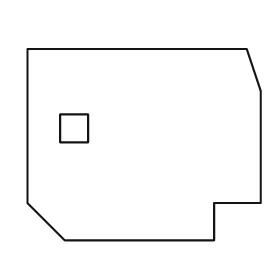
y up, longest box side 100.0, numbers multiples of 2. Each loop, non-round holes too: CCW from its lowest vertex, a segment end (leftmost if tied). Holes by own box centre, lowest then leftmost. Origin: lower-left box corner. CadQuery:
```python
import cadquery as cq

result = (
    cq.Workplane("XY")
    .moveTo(16.0, 0.0)
    .lineTo(80.0, 0.0)
    .lineTo(80.0, 16.0)
    .lineTo(100.0, 16.0)
    .lineTo(100.0, 64.0)
    .lineTo(94.0, 82.0)
    .lineTo(0.0, 82.0)
    .lineTo(0.0, 16.0)
    .close()
    .moveTo(14.0, 42.0)
    .lineTo(26.0, 42.0)
    .lineTo(26.0, 54.0)
    .lineTo(14.0, 54.0)
    .close()
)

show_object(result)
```